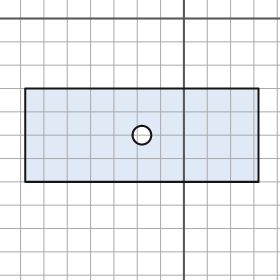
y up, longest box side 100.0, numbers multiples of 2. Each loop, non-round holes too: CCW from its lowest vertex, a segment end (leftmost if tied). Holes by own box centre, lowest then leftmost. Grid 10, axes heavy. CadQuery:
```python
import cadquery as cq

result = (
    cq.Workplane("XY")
    .moveTo(-68.0, -70.0)
    .lineTo(32.0, -70.0)
    .lineTo(32.0, -30.0)
    .lineTo(-68.0, -30.0)
    .close()
    .moveTo(-18.0, -50.0)
    .circle(4.0)
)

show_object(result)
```